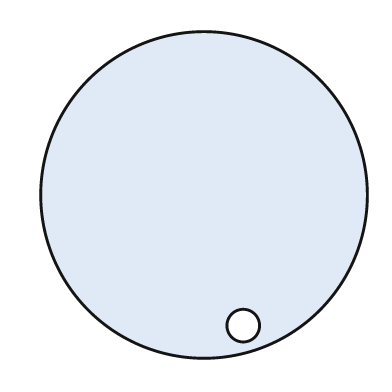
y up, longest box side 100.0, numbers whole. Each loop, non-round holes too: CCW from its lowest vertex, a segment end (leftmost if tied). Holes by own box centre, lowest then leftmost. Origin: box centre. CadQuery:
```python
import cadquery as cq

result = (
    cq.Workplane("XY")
    .moveTo(0.0, 0.0)
    .circle(50.0)
    .moveTo(12.0, -40.0)
    .circle(5.0)
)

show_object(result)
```